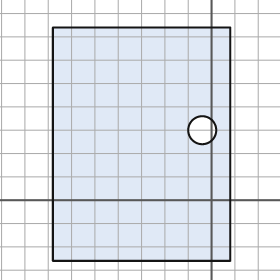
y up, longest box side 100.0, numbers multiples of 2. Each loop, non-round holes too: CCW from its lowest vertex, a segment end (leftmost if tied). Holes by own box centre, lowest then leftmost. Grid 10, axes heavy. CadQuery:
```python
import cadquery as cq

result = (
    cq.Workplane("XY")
    .moveTo(-68.0, -26.0)
    .lineTo(8.0, -26.0)
    .lineTo(8.0, 74.0)
    .lineTo(-68.0, 74.0)
    .close()
    .moveTo(-4.0, 30.0)
    .circle(6.0)
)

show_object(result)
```